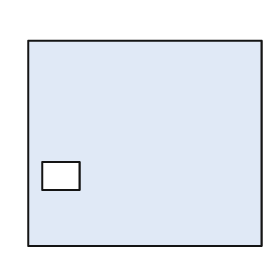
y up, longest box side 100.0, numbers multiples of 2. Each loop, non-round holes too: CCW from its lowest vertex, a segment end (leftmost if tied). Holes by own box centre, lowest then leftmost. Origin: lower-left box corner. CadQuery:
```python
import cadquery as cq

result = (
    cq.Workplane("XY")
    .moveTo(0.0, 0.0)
    .lineTo(100.0, 0.0)
    .lineTo(100.0, 88.0)
    .lineTo(0.0, 88.0)
    .close()
    .moveTo(6.0, 24.0)
    .lineTo(22.0, 24.0)
    .lineTo(22.0, 36.0)
    .lineTo(6.0, 36.0)
    .close()
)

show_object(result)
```